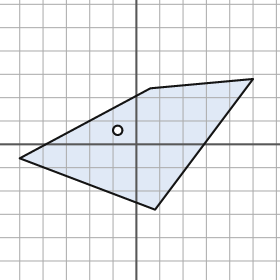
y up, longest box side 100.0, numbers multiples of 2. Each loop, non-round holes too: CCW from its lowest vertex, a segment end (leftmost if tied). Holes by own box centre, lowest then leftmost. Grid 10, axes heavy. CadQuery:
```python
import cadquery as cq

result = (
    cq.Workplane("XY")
    .moveTo(8.0, -28.0)
    .lineTo(50.0, 28.0)
    .lineTo(6.0, 24.0)
    .lineTo(-50.0, -6.0)
    .close()
    .moveTo(-8.0, 6.0)
    .circle(2.0)
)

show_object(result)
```